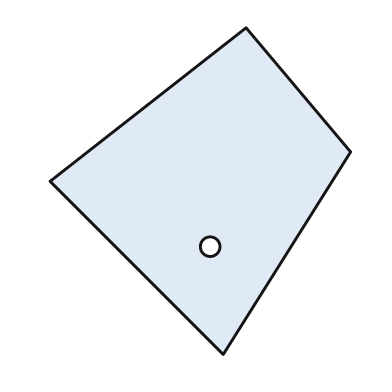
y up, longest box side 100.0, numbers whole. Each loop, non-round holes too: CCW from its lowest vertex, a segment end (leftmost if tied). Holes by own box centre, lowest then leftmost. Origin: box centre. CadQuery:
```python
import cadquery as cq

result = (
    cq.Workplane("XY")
    .moveTo(7.0, -50.0)
    .lineTo(46.0, 12.0)
    .lineTo(14.0, 50.0)
    .lineTo(-46.0, 3.0)
    .close()
    .moveTo(3.0, -17.0)
    .circle(3.0)
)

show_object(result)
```